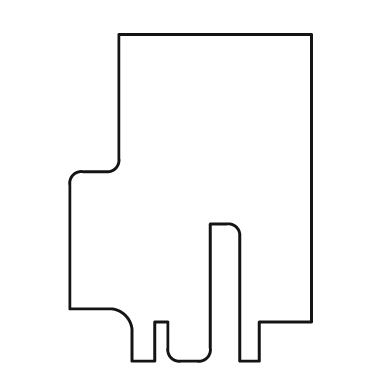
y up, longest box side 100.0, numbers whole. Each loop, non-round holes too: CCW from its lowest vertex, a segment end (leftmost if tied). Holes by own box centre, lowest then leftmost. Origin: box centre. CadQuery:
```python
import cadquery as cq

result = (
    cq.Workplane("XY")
    .moveTo(-18.0, -50.0)
    .lineTo(-11.0, -50.0)
    .lineTo(-11.0, -38.0)
    .lineTo(-7.0, -38.0)
    .lineTo(-7.0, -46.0)
    .threePointArc((-6.0, -49.0), (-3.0, -50.0))
    .lineTo(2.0, -50.0)
    .threePointArc((5.0, -49.0), (6.0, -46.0))
    .lineTo(6.0, -8.0)
    .lineTo(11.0, -8.0)
    .threePointArc((14.0, -9.0), (15.0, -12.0))
    .lineTo(15.0, -50.0)
    .lineTo(21.0, -50.0)
    .lineTo(21.0, -38.0)
    .lineTo(37.0, -38.0)
    .lineTo(37.0, 50.0)
    .lineTo(-22.0, 50.0)
    .lineTo(-22.0, 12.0)
    .threePointArc((-23.0, 9.0), (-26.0, 8.0))
    .lineTo(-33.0, 8.0)
    .threePointArc((-36.0, 7.0), (-37.0, 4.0))
    .lineTo(-37.0, -34.0)
    .lineTo(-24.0, -34.0)
    .threePointArc((-20.0, -36.0), (-18.0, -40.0))
    .close()
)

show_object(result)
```